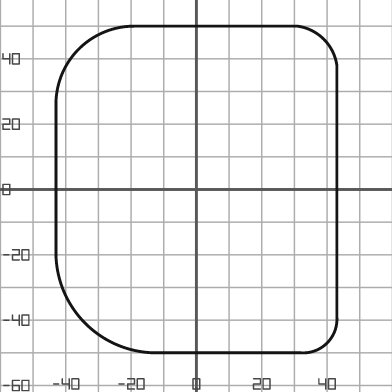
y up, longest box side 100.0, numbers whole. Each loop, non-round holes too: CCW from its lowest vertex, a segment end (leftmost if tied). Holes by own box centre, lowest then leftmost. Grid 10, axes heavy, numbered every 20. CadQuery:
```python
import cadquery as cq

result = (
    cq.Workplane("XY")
    .moveTo(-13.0, -50.0)
    .lineTo(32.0, -50.0)
    .threePointArc((40.0, -47.0), (43.0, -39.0))
    .lineTo(43.0, 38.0)
    .threePointArc((39.0, 46.0), (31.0, 50.0))
    .lineTo(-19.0, 50.0)
    .threePointArc((-36.0, 43.0), (-43.0, 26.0))
    .lineTo(-43.0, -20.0)
    .threePointArc((-34.0, -41.0), (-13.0, -50.0))
    .close()
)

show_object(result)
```